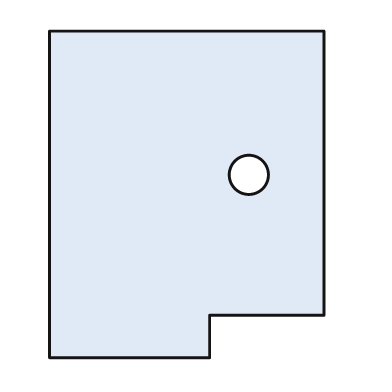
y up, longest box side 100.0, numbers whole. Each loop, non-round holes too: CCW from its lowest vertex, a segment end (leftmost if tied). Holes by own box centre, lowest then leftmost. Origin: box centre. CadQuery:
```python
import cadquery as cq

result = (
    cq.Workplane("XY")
    .moveTo(-42.0, -50.0)
    .lineTo(7.0, -50.0)
    .lineTo(7.0, -37.0)
    .lineTo(42.0, -37.0)
    .lineTo(42.0, 50.0)
    .lineTo(-42.0, 50.0)
    .close()
    .moveTo(19.0, 6.0)
    .circle(6.0)
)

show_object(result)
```